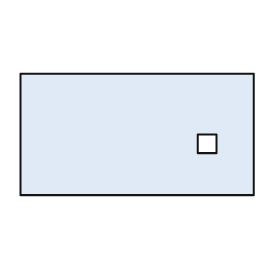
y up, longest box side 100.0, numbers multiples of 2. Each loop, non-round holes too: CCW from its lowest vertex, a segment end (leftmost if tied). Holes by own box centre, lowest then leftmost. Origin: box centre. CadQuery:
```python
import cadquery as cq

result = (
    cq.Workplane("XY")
    .moveTo(-50.0, -26.0)
    .lineTo(50.0, -26.0)
    .lineTo(50.0, 26.0)
    .lineTo(-50.0, 26.0)
    .close()
    .moveTo(26.0, -8.0)
    .lineTo(34.0, -8.0)
    .lineTo(34.0, 0.0)
    .lineTo(26.0, 0.0)
    .close()
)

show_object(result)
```